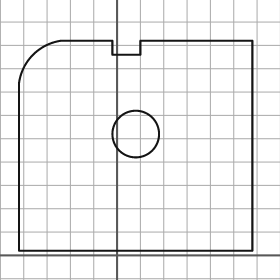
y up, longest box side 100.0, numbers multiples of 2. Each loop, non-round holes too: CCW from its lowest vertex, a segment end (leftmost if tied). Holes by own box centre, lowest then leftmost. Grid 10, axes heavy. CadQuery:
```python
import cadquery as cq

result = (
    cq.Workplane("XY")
    .moveTo(-42.0, 2.0)
    .lineTo(58.0, 2.0)
    .lineTo(58.0, 92.0)
    .lineTo(10.0, 92.0)
    .lineTo(10.0, 86.0)
    .lineTo(-2.0, 86.0)
    .lineTo(-2.0, 92.0)
    .lineTo(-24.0, 92.0)
    .threePointArc((-36.0, 86.0), (-42.0, 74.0))
    .close()
    .moveTo(8.0, 52.0)
    .circle(10.0)
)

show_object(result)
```